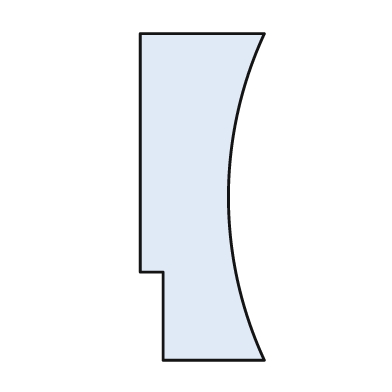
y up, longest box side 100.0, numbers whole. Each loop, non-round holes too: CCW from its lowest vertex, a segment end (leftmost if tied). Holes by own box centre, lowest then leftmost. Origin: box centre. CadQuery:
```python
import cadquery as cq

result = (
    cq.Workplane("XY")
    .moveTo(-12.0, -50.0)
    .lineTo(19.0, -50.0)
    .threePointArc((8.0, 0.0), (19.0, 50.0))
    .lineTo(-19.0, 50.0)
    .lineTo(-19.0, -23.0)
    .lineTo(-12.0, -23.0)
    .close()
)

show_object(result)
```